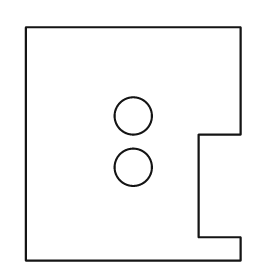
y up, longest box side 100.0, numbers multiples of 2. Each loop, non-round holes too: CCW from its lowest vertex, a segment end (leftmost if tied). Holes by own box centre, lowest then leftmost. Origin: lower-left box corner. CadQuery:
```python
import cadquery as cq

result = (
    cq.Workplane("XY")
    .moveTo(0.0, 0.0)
    .lineTo(92.0, 0.0)
    .lineTo(92.0, 10.0)
    .lineTo(74.0, 10.0)
    .lineTo(74.0, 54.0)
    .lineTo(92.0, 54.0)
    .lineTo(92.0, 100.0)
    .lineTo(0.0, 100.0)
    .close()
    .moveTo(46.0, 40.0)
    .circle(8.0)
    .moveTo(46.0, 62.0)
    .circle(8.0)
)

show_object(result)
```